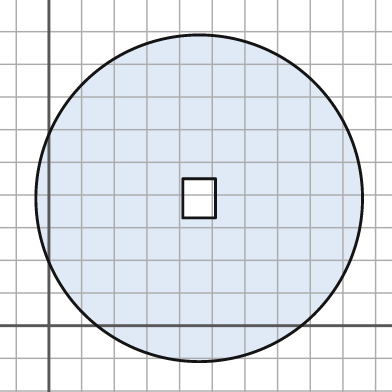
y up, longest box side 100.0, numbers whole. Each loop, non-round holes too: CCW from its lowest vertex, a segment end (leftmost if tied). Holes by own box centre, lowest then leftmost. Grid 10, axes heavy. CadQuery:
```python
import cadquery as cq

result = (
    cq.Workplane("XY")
    .moveTo(46.0, 39.0)
    .circle(50.0)
    .moveTo(41.0, 33.0)
    .lineTo(51.0, 33.0)
    .lineTo(51.0, 45.0)
    .lineTo(41.0, 45.0)
    .close()
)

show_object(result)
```